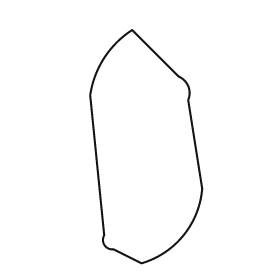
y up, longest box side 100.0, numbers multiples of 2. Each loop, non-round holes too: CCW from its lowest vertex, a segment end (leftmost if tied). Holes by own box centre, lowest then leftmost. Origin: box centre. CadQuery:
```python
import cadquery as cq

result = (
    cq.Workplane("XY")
    .moveTo(-2.0, -50.0)
    .threePointArc((16.0, -38.0), (24.0, -18.0))
    .lineTo(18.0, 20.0)
    .threePointArc((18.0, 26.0), (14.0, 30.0))
    .lineTo(-6.0, 50.0)
    .threePointArc((-18.0, 38.0), (-24.0, 22.0))
    .lineTo(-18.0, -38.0)
    .threePointArc((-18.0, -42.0), (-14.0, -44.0))
    .close()
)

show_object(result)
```